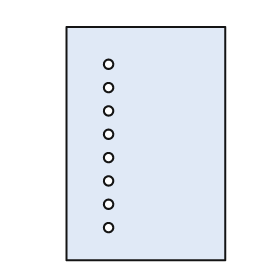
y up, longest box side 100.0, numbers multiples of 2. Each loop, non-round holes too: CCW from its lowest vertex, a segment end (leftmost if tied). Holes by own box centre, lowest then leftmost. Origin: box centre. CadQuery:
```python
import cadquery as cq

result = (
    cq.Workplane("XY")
    .moveTo(-34.0, -50.0)
    .lineTo(34.0, -50.0)
    .lineTo(34.0, 50.0)
    .lineTo(-34.0, 50.0)
    .close()
    .moveTo(-16.0, -36.0)
    .circle(2.0)
    .moveTo(-16.0, -26.0)
    .circle(2.0)
    .moveTo(-16.0, -16.0)
    .circle(2.0)
    .moveTo(-16.0, -6.0)
    .circle(2.0)
    .moveTo(-16.0, 4.0)
    .circle(2.0)
    .moveTo(-16.0, 14.0)
    .circle(2.0)
    .moveTo(-16.0, 24.0)
    .circle(2.0)
    .moveTo(-16.0, 34.0)
    .circle(2.0)
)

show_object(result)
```